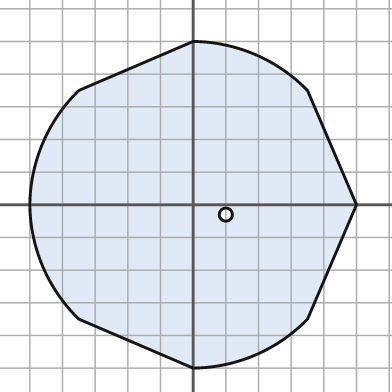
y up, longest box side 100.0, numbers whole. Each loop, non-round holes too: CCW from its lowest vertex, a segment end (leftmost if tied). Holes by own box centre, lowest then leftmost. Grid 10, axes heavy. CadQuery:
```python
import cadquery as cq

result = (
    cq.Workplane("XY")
    .moveTo(0.0, -50.0)
    .threePointArc((19.0, -46.0), (35.0, -35.0))
    .lineTo(50.0, 0.0)
    .lineTo(35.0, 35.0)
    .threePointArc((19.0, 46.0), (0.0, 50.0))
    .lineTo(-35.0, 35.0)
    .threePointArc((-46.0, 19.0), (-50.0, 0.0))
    .threePointArc((-46.0, -19.0), (-35.0, -35.0))
    .close()
    .moveTo(10.0, -3.0)
    .circle(2.0)
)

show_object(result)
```